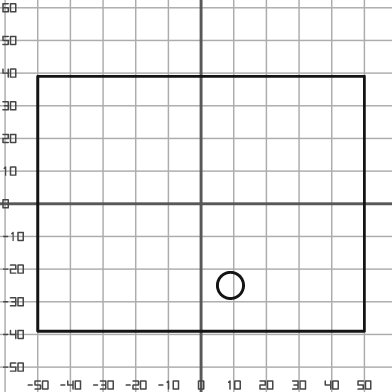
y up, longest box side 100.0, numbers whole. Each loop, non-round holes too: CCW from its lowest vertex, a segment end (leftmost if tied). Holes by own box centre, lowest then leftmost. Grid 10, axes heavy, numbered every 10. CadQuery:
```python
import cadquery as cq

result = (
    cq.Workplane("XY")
    .moveTo(-50.0, -39.0)
    .lineTo(50.0, -39.0)
    .lineTo(50.0, 39.0)
    .lineTo(-50.0, 39.0)
    .close()
    .moveTo(9.0, -25.0)
    .circle(4.0)
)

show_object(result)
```